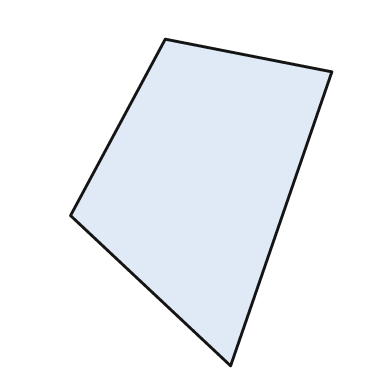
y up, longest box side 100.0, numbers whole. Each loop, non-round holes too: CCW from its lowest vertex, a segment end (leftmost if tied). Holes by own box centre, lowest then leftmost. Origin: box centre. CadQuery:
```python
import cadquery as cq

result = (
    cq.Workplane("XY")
    .moveTo(9.0, -50.0)
    .lineTo(40.0, 40.0)
    .lineTo(-11.0, 50.0)
    .lineTo(-40.0, -4.0)
    .close()
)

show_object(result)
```